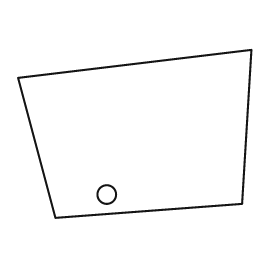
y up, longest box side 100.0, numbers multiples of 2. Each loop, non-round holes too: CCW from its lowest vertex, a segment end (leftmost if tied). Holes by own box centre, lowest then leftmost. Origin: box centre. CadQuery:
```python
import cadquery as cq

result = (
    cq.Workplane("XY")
    .moveTo(-34.0, -36.0)
    .lineTo(46.0, -30.0)
    .lineTo(50.0, 36.0)
    .lineTo(-50.0, 24.0)
    .close()
    .moveTo(-12.0, -26.0)
    .circle(4.0)
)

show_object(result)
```